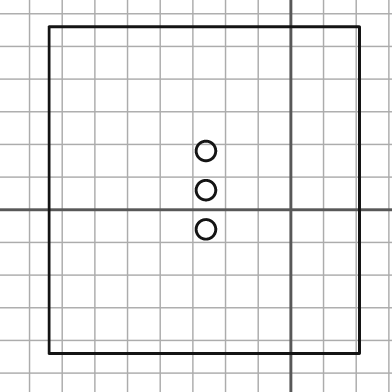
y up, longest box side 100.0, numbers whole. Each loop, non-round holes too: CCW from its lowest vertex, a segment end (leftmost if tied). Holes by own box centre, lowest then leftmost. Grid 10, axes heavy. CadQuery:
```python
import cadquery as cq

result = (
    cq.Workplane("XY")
    .moveTo(-74.0, -44.0)
    .lineTo(21.0, -44.0)
    .lineTo(21.0, 56.0)
    .lineTo(-74.0, 56.0)
    .close()
    .moveTo(-26.0, -6.0)
    .circle(3.0)
    .moveTo(-26.0, 6.0)
    .circle(3.0)
    .moveTo(-26.0, 18.0)
    .circle(3.0)
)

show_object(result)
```